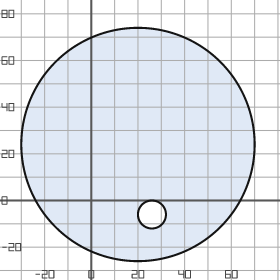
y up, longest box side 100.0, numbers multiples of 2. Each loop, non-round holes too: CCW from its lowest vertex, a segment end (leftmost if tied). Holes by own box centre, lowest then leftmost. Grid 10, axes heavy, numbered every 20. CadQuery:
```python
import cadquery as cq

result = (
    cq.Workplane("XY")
    .moveTo(20.0, 24.0)
    .circle(50.0)
    .moveTo(26.0, -6.0)
    .circle(6.0)
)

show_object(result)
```